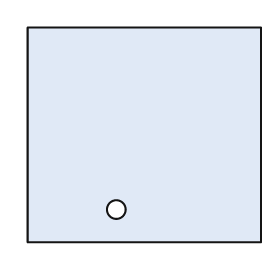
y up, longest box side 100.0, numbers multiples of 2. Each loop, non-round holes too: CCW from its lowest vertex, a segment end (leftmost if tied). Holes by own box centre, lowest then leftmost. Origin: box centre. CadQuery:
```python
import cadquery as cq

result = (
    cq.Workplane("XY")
    .moveTo(-50.0, -46.0)
    .lineTo(50.0, -46.0)
    .lineTo(50.0, 46.0)
    .lineTo(-50.0, 46.0)
    .close()
    .moveTo(-12.0, -32.0)
    .circle(4.0)
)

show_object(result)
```